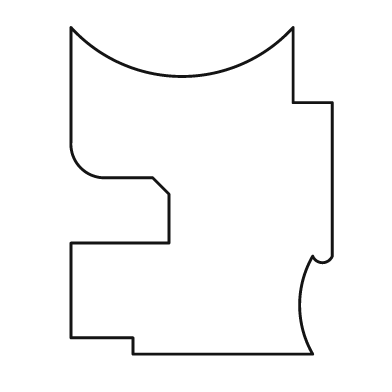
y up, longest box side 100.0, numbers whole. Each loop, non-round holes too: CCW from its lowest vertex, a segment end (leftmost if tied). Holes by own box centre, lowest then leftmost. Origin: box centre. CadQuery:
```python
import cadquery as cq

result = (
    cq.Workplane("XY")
    .moveTo(-21.0, -50.0)
    .lineTo(34.0, -50.0)
    .threePointArc((30.0, -35.0), (34.0, -20.0))
    .threePointArc((37.0, -22.0), (40.0, -20.0))
    .lineTo(40.0, 27.0)
    .lineTo(28.0, 27.0)
    .lineTo(28.0, 50.0)
    .threePointArc((-6.0, 35.0), (-40.0, 50.0))
    .lineTo(-40.0, 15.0)
    .threePointArc((-37.0, 7.0), (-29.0, 4.0))
    .lineTo(-15.0, 4.0)
    .lineTo(-10.0, -1.0)
    .lineTo(-10.0, -16.0)
    .lineTo(-40.0, -16.0)
    .lineTo(-40.0, -45.0)
    .lineTo(-21.0, -45.0)
    .close()
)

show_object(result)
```